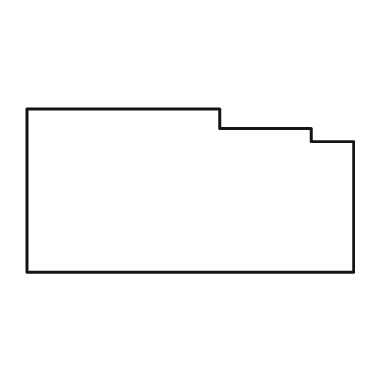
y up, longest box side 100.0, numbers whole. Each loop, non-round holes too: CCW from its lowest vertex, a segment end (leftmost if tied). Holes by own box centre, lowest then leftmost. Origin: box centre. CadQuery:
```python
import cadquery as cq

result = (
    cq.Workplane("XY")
    .moveTo(-50.0, -25.0)
    .lineTo(50.0, -25.0)
    .lineTo(50.0, 15.0)
    .lineTo(37.0, 15.0)
    .lineTo(37.0, 19.0)
    .lineTo(9.0, 19.0)
    .lineTo(9.0, 25.0)
    .lineTo(-50.0, 25.0)
    .close()
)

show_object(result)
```